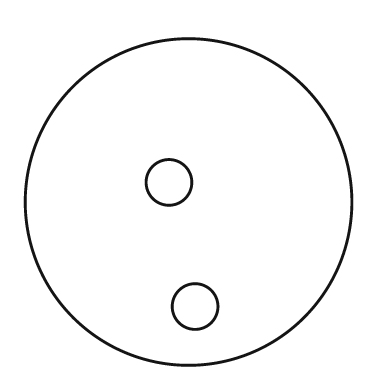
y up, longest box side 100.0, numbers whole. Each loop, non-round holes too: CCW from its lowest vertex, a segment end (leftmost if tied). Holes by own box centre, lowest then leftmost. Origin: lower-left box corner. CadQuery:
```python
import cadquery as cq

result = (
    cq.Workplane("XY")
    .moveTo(50.0, 50.0)
    .circle(50.0)
    .moveTo(52.0, 18.0)
    .circle(7.0)
    .moveTo(44.0, 56.0)
    .circle(7.0)
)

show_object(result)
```